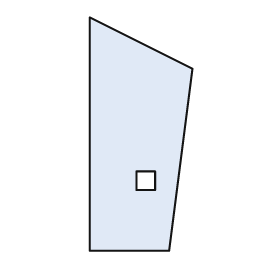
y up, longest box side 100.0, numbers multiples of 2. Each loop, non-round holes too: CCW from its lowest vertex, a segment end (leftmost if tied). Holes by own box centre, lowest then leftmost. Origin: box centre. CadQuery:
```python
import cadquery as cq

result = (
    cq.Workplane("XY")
    .moveTo(-22.0, -50.0)
    .lineTo(12.0, -50.0)
    .lineTo(22.0, 28.0)
    .lineTo(-22.0, 50.0)
    .close()
    .moveTo(-2.0, -24.0)
    .lineTo(6.0, -24.0)
    .lineTo(6.0, -16.0)
    .lineTo(-2.0, -16.0)
    .close()
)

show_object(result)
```